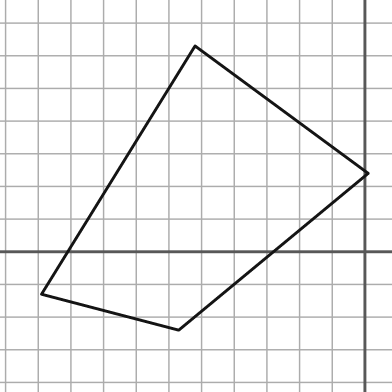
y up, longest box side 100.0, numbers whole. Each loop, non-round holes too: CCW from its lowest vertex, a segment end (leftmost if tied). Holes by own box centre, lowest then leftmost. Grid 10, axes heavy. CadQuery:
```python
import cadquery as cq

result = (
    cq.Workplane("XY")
    .moveTo(-57.0, -24.0)
    .lineTo(1.0, 24.0)
    .lineTo(-52.0, 63.0)
    .lineTo(-99.0, -13.0)
    .close()
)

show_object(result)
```